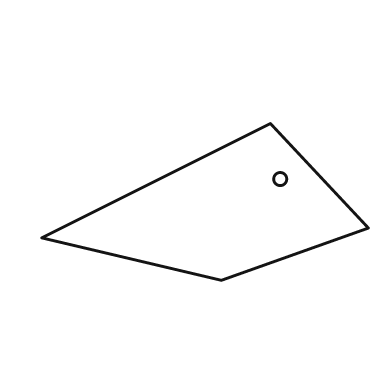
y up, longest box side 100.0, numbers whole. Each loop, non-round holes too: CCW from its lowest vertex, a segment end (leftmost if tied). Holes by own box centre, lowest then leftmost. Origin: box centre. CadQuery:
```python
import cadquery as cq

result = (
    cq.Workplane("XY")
    .moveTo(5.0, -24.0)
    .lineTo(50.0, -8.0)
    .lineTo(20.0, 24.0)
    .lineTo(-50.0, -11.0)
    .close()
    .moveTo(23.0, 7.0)
    .circle(2.0)
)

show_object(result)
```